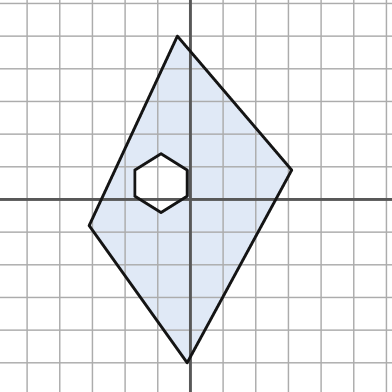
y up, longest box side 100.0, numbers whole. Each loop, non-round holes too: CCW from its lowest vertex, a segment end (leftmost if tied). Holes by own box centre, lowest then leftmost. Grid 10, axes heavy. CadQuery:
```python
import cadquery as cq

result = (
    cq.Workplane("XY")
    .moveTo(-1.0, -50.0)
    .lineTo(31.0, 9.0)
    .lineTo(-4.0, 50.0)
    .lineTo(-31.0, -8.0)
    .close()
    .moveTo(-9.0, -4.0)
    .lineTo(-1.0, 1.0)
    .lineTo(-1.0, 9.0)
    .lineTo(-9.0, 14.0)
    .lineTo(-17.0, 9.0)
    .lineTo(-17.0, 1.0)
    .close()
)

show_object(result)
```